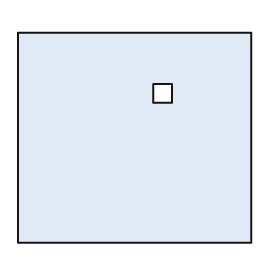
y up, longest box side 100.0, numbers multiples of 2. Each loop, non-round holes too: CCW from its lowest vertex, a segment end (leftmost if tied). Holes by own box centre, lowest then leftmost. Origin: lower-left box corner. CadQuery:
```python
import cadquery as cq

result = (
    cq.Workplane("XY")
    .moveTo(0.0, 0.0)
    .lineTo(100.0, 0.0)
    .lineTo(100.0, 90.0)
    .lineTo(0.0, 90.0)
    .close()
    .moveTo(58.0, 60.0)
    .lineTo(66.0, 60.0)
    .lineTo(66.0, 68.0)
    .lineTo(58.0, 68.0)
    .close()
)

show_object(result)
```